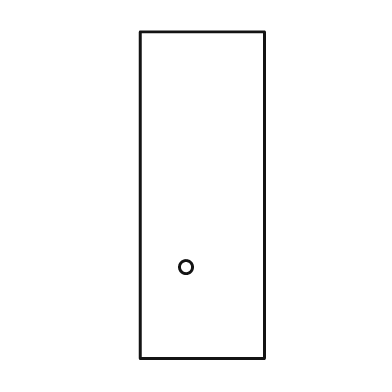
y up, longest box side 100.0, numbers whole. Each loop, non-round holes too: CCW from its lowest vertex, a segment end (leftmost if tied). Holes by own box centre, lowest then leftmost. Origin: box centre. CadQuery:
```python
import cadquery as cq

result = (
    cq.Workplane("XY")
    .moveTo(-19.0, -50.0)
    .lineTo(19.0, -50.0)
    .lineTo(19.0, 50.0)
    .lineTo(-19.0, 50.0)
    .close()
    .moveTo(-5.0, -22.0)
    .circle(2.0)
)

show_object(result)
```